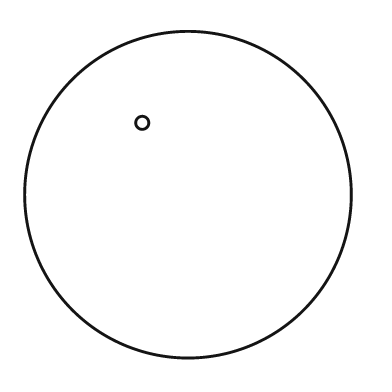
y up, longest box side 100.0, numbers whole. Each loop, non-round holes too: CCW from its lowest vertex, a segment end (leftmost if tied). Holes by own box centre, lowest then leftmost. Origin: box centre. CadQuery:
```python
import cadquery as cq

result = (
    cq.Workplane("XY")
    .moveTo(0.0, 0.0)
    .circle(50.0)
    .moveTo(-14.0, 22.0)
    .circle(2.0)
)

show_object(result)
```